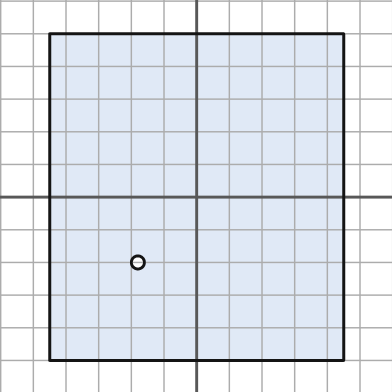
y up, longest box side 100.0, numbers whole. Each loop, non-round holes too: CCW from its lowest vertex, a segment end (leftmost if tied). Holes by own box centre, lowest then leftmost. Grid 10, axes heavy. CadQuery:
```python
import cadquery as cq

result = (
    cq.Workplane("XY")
    .moveTo(-45.0, -50.0)
    .lineTo(45.0, -50.0)
    .lineTo(45.0, 50.0)
    .lineTo(-45.0, 50.0)
    .close()
    .moveTo(-18.0, -20.0)
    .circle(2.0)
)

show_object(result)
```